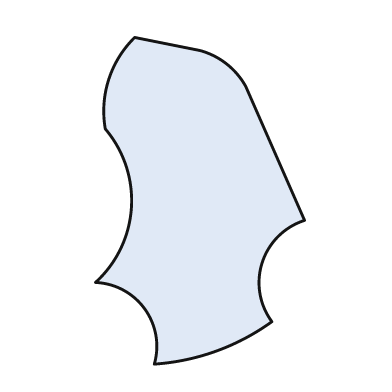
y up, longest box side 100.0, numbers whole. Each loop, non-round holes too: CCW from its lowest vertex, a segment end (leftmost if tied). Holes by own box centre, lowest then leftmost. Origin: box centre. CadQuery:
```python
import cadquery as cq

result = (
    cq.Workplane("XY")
    .moveTo(-14.0, -50.0)
    .threePointArc((5.0, -46.0), (22.0, -37.0))
    .threePointArc((19.0, -19.0), (32.0, -6.0))
    .lineTo(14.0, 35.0)
    .threePointArc((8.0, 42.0), (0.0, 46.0))
    .lineTo(-20.0, 50.0)
    .threePointArc((-28.0, 37.0), (-29.0, 22.0))
    .threePointArc((-21.0, -2.0), (-32.0, -25.0))
    .threePointArc((-17.0, -33.0), (-14.0, -50.0))
    .close()
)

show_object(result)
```